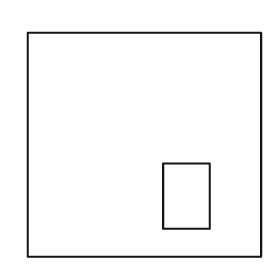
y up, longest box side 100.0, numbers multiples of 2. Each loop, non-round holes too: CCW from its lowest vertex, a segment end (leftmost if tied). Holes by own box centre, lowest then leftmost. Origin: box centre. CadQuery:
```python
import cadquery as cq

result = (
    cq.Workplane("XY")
    .moveTo(-50.0, -48.0)
    .lineTo(50.0, -48.0)
    .lineTo(50.0, 48.0)
    .lineTo(-50.0, 48.0)
    .close()
    .moveTo(8.0, -36.0)
    .lineTo(28.0, -36.0)
    .lineTo(28.0, -8.0)
    .lineTo(8.0, -8.0)
    .close()
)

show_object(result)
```